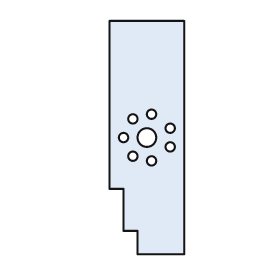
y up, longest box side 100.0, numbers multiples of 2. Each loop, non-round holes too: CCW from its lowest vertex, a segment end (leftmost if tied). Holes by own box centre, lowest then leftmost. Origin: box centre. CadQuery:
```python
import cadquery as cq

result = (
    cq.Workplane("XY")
    .moveTo(-4.0, -50.0)
    .lineTo(16.0, -50.0)
    .lineTo(16.0, 50.0)
    .lineTo(-16.0, 50.0)
    .lineTo(-16.0, -22.0)
    .lineTo(-10.0, -22.0)
    .lineTo(-10.0, -40.0)
    .lineTo(-4.0, -40.0)
    .close()
    .moveTo(2.0, -10.0)
    .circle(2.0)
    .moveTo(-6.0, -8.0)
    .circle(2.0)
    .moveTo(10.0, -4.0)
    .circle(2.0)
    .moveTo(-10.0, 0.0)
    .circle(2.0)
    .moveTo(0.0, 0.0)
    .circle(4.0)
    .moveTo(10.0, 4.0)
    .circle(2.0)
    .moveTo(-6.0, 8.0)
    .circle(2.0)
    .moveTo(2.0, 10.0)
    .circle(2.0)
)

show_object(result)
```